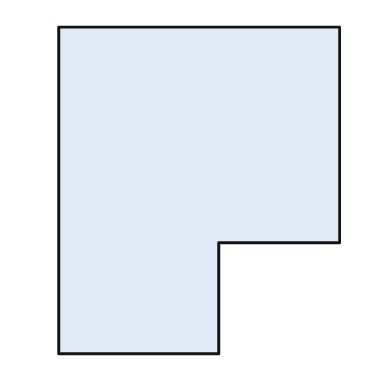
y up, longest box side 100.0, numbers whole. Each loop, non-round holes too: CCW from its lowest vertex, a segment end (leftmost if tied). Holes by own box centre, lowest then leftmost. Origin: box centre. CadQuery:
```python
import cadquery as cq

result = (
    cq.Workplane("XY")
    .moveTo(-43.0, -50.0)
    .lineTo(6.0, -50.0)
    .lineTo(6.0, -16.0)
    .lineTo(43.0, -16.0)
    .lineTo(43.0, 50.0)
    .lineTo(-43.0, 50.0)
    .close()
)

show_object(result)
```